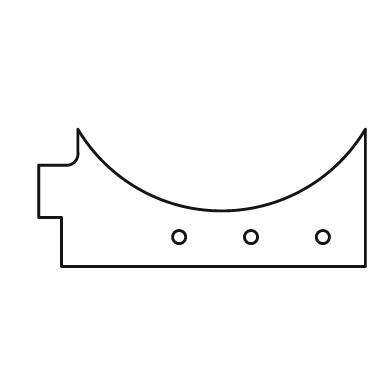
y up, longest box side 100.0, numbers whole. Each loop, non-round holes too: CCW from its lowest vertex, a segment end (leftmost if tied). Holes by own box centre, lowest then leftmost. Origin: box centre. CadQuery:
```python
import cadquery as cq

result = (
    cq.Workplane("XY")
    .moveTo(-43.0, -21.0)
    .lineTo(50.0, -21.0)
    .lineTo(50.0, 21.0)
    .threePointArc((6.0, -4.0), (-38.0, 21.0))
    .lineTo(-38.0, 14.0)
    .threePointArc((-39.0, 11.0), (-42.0, 10.0))
    .lineTo(-50.0, 10.0)
    .lineTo(-50.0, -6.0)
    .lineTo(-43.0, -6.0)
    .close()
    .moveTo(-7.0, -12.0)
    .circle(2.0)
    .moveTo(15.0, -12.0)
    .circle(2.0)
    .moveTo(37.0, -12.0)
    .circle(2.0)
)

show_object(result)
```